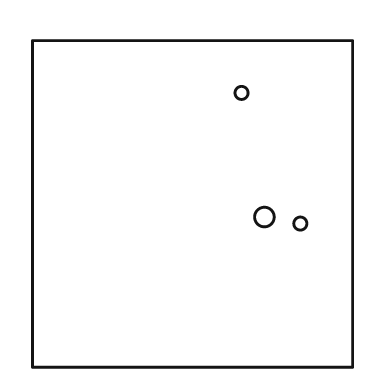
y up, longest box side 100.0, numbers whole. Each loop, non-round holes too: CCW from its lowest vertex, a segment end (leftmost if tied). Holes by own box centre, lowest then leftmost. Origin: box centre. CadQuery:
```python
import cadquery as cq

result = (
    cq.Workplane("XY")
    .moveTo(-49.0, -50.0)
    .lineTo(49.0, -50.0)
    .lineTo(49.0, 50.0)
    .lineTo(-49.0, 50.0)
    .close()
    .moveTo(33.0, -6.0)
    .circle(2.0)
    .moveTo(22.0, -4.0)
    .circle(3.0)
    .moveTo(15.0, 34.0)
    .circle(2.0)
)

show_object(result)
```